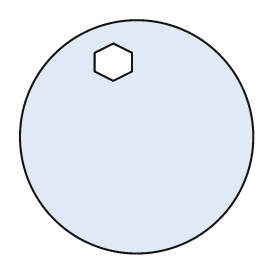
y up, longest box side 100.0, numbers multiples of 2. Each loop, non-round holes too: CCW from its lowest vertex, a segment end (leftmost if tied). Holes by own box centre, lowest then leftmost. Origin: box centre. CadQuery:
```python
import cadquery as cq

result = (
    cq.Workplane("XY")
    .moveTo(0.0, 0.0)
    .circle(50.0)
    .moveTo(-10.0, 24.0)
    .lineTo(-2.0, 28.0)
    .lineTo(-2.0, 36.0)
    .lineTo(-10.0, 40.0)
    .lineTo(-18.0, 36.0)
    .lineTo(-18.0, 28.0)
    .close()
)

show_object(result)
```